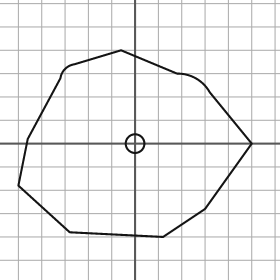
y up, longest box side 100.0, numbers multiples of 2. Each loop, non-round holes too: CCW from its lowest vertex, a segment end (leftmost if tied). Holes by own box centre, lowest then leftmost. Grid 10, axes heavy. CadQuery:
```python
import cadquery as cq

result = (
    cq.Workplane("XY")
    .moveTo(12.0, -40.0)
    .lineTo(30.0, -28.0)
    .lineTo(50.0, 0.0)
    .lineTo(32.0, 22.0)
    .threePointArc((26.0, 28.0), (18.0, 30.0))
    .lineTo(-6.0, 40.0)
    .lineTo(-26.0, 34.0)
    .threePointArc((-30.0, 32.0), (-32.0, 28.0))
    .lineTo(-46.0, 2.0)
    .lineTo(-50.0, -18.0)
    .lineTo(-28.0, -38.0)
    .close()
    .moveTo(0.0, 0.0)
    .circle(4.0)
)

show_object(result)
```